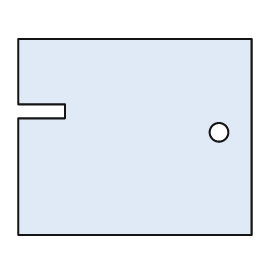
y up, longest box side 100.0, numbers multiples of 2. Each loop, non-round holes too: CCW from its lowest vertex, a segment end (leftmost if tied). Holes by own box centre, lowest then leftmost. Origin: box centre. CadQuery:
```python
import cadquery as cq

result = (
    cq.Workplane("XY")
    .moveTo(-50.0, -42.0)
    .lineTo(50.0, -42.0)
    .lineTo(50.0, 42.0)
    .lineTo(-50.0, 42.0)
    .lineTo(-50.0, 14.0)
    .lineTo(-30.0, 14.0)
    .lineTo(-30.0, 8.0)
    .lineTo(-50.0, 8.0)
    .close()
    .moveTo(36.0, 2.0)
    .circle(4.0)
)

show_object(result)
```